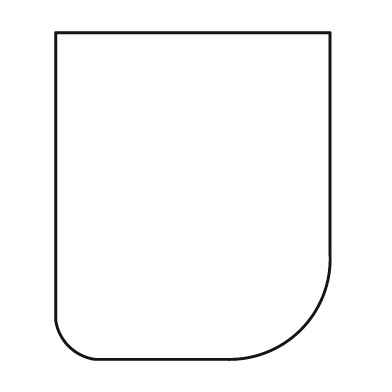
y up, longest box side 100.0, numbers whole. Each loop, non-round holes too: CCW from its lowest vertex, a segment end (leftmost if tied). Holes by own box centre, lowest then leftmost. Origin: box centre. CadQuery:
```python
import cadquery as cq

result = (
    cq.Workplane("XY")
    .moveTo(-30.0, -50.0)
    .lineTo(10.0, -50.0)
    .threePointArc((33.0, -41.0), (42.0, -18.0))
    .lineTo(42.0, 50.0)
    .lineTo(-42.0, 50.0)
    .lineTo(-42.0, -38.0)
    .threePointArc((-38.0, -46.0), (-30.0, -50.0))
    .close()
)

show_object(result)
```